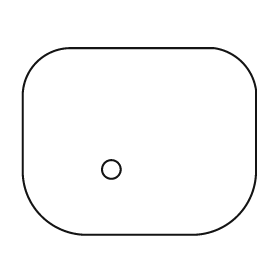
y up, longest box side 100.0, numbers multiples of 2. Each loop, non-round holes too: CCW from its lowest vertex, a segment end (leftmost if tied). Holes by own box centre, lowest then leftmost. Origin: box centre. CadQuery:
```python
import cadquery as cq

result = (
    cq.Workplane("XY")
    .moveTo(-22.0, -40.0)
    .lineTo(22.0, -40.0)
    .threePointArc((42.0, -32.0), (50.0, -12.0))
    .lineTo(50.0, 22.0)
    .threePointArc((44.0, 34.0), (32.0, 40.0))
    .lineTo(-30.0, 40.0)
    .threePointArc((-44.0, 34.0), (-50.0, 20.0))
    .lineTo(-50.0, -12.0)
    .threePointArc((-42.0, -32.0), (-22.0, -40.0))
    .close()
    .moveTo(-12.0, -12.0)
    .circle(4.0)
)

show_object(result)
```